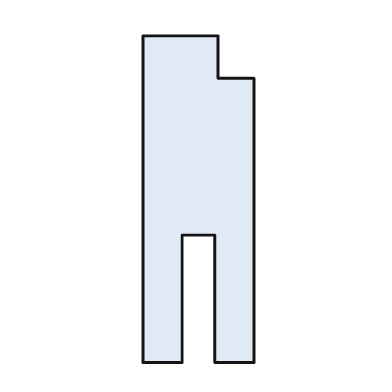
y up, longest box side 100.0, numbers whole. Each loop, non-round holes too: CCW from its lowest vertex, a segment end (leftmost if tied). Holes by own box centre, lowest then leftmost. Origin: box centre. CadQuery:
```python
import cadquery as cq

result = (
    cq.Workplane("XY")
    .moveTo(-17.0, -50.0)
    .lineTo(-5.0, -50.0)
    .lineTo(-5.0, -11.0)
    .lineTo(5.0, -11.0)
    .lineTo(5.0, -50.0)
    .lineTo(17.0, -50.0)
    .lineTo(17.0, 37.0)
    .lineTo(6.0, 37.0)
    .lineTo(6.0, 50.0)
    .lineTo(-17.0, 50.0)
    .close()
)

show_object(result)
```